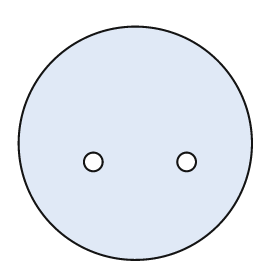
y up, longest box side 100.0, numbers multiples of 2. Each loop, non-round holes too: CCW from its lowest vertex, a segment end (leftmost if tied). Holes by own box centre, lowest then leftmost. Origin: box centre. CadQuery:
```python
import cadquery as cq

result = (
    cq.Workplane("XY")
    .moveTo(0.0, 0.0)
    .circle(50.0)
    .moveTo(-18.0, -8.0)
    .circle(4.0)
    .moveTo(22.0, -8.0)
    .circle(4.0)
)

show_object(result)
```